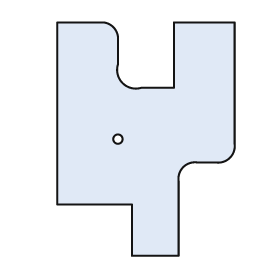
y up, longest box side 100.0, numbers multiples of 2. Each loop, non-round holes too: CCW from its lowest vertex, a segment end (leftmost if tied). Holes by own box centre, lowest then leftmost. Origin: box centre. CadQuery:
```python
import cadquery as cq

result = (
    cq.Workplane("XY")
    .moveTo(-6.0, -50.0)
    .lineTo(14.0, -50.0)
    .lineTo(14.0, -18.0)
    .threePointArc((16.0, -12.0), (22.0, -10.0))
    .lineTo(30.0, -10.0)
    .threePointArc((36.0, -8.0), (38.0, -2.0))
    .lineTo(38.0, 50.0)
    .lineTo(12.0, 50.0)
    .lineTo(12.0, 22.0)
    .lineTo(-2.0, 22.0)
    .threePointArc((-10.0, 24.0), (-12.0, 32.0))
    .lineTo(-12.0, 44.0)
    .threePointArc((-14.0, 48.0), (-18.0, 50.0))
    .lineTo(-38.0, 50.0)
    .lineTo(-38.0, -28.0)
    .lineTo(-6.0, -28.0)
    .close()
    .moveTo(-12.0, 0.0)
    .circle(2.0)
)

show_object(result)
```